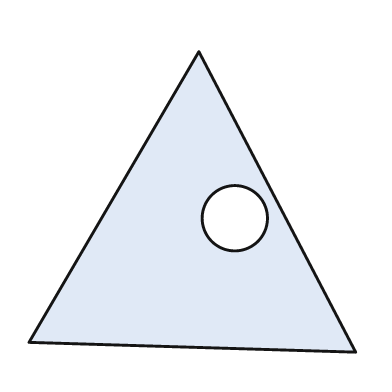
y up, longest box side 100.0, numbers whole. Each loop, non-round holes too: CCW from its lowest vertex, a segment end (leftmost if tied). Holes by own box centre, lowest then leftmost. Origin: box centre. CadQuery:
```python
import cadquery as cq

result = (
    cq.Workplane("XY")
    .moveTo(50.0, -46.0)
    .lineTo(2.0, 46.0)
    .lineTo(-50.0, -43.0)
    .close()
    .moveTo(13.0, -5.0)
    .circle(10.0)
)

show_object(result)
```